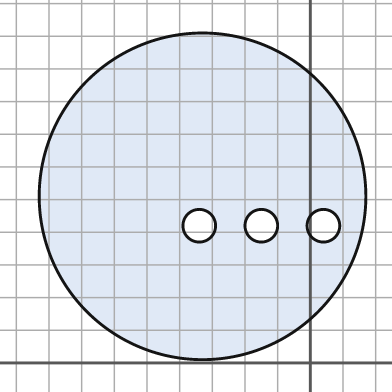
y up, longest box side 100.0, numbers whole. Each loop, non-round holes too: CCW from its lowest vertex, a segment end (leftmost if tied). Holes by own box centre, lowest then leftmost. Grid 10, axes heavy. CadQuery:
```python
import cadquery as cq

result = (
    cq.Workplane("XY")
    .moveTo(-33.0, 51.0)
    .circle(50.0)
    .moveTo(-34.0, 42.0)
    .circle(5.0)
    .moveTo(-15.0, 42.0)
    .circle(5.0)
    .moveTo(4.0, 42.0)
    .circle(5.0)
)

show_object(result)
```